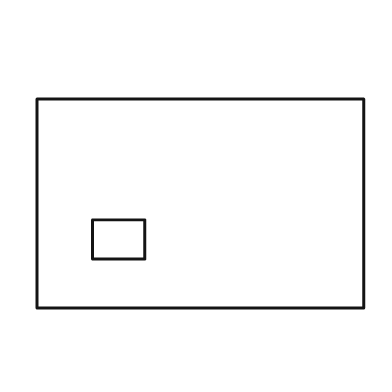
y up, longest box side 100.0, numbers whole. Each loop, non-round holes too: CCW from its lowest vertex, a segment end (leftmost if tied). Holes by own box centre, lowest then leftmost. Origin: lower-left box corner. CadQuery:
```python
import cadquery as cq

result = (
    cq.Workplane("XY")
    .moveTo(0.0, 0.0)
    .lineTo(100.0, 0.0)
    .lineTo(100.0, 64.0)
    .lineTo(0.0, 64.0)
    .close()
    .moveTo(17.0, 15.0)
    .lineTo(33.0, 15.0)
    .lineTo(33.0, 27.0)
    .lineTo(17.0, 27.0)
    .close()
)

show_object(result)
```